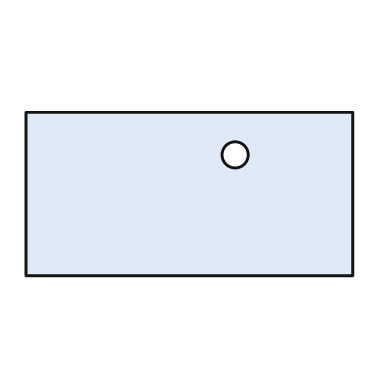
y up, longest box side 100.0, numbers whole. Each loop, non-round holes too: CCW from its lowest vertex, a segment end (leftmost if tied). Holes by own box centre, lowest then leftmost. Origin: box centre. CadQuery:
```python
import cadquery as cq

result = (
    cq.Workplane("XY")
    .moveTo(-50.0, -25.0)
    .lineTo(50.0, -25.0)
    .lineTo(50.0, 25.0)
    .lineTo(-50.0, 25.0)
    .close()
    .moveTo(14.0, 12.0)
    .circle(4.0)
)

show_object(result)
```